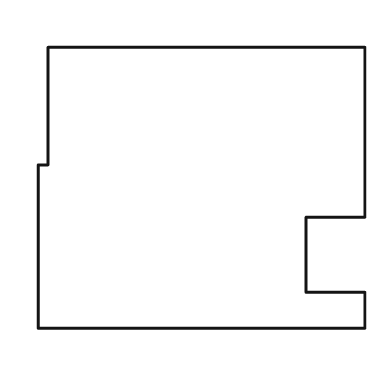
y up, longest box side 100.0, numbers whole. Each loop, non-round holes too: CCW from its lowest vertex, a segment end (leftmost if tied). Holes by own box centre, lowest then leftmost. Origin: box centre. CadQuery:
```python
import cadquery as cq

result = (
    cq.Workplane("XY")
    .moveTo(-50.0, -43.0)
    .lineTo(50.0, -43.0)
    .lineTo(50.0, -32.0)
    .lineTo(32.0, -32.0)
    .lineTo(32.0, -9.0)
    .lineTo(50.0, -9.0)
    .lineTo(50.0, 43.0)
    .lineTo(-47.0, 43.0)
    .lineTo(-47.0, 7.0)
    .lineTo(-50.0, 7.0)
    .close()
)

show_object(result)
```